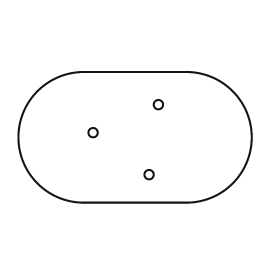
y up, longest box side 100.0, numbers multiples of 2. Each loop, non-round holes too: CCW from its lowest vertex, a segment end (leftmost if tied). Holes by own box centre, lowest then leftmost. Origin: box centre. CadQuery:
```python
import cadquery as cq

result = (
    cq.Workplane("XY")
    .moveTo(-22.0, -28.0)
    .lineTo(22.0, -28.0)
    .threePointArc((50.0, 0.0), (22.0, 28.0))
    .lineTo(-22.0, 28.0)
    .threePointArc((-50.0, 0.0), (-22.0, -28.0))
    .close()
    .moveTo(6.0, -16.0)
    .circle(2.0)
    .moveTo(-18.0, 2.0)
    .circle(2.0)
    .moveTo(10.0, 14.0)
    .circle(2.0)
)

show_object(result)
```